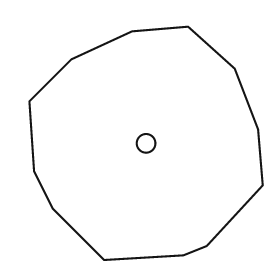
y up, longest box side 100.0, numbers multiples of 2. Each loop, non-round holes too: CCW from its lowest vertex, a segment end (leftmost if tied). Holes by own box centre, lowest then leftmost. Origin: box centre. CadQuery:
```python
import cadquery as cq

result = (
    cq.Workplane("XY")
    .moveTo(-18.0, -50.0)
    .lineTo(16.0, -48.0)
    .lineTo(26.0, -44.0)
    .lineTo(50.0, -18.0)
    .lineTo(48.0, 6.0)
    .lineTo(38.0, 32.0)
    .lineTo(18.0, 50.0)
    .lineTo(-6.0, 48.0)
    .lineTo(-32.0, 36.0)
    .lineTo(-50.0, 18.0)
    .lineTo(-48.0, -12.0)
    .lineTo(-40.0, -28.0)
    .close()
    .moveTo(0.0, 0.0)
    .circle(4.0)
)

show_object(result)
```